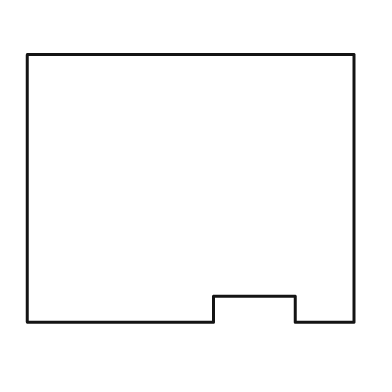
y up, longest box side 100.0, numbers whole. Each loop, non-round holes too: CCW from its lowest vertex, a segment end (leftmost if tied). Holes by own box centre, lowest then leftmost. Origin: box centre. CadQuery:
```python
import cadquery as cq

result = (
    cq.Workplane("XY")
    .moveTo(-50.0, -41.0)
    .lineTo(7.0, -41.0)
    .lineTo(7.0, -33.0)
    .lineTo(32.0, -33.0)
    .lineTo(32.0, -41.0)
    .lineTo(50.0, -41.0)
    .lineTo(50.0, 41.0)
    .lineTo(-50.0, 41.0)
    .close()
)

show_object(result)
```